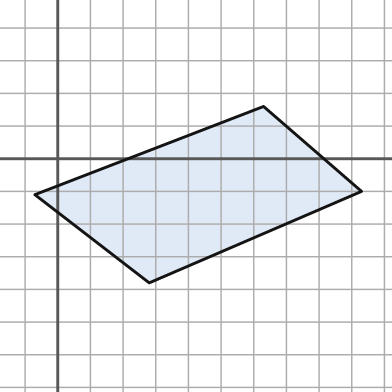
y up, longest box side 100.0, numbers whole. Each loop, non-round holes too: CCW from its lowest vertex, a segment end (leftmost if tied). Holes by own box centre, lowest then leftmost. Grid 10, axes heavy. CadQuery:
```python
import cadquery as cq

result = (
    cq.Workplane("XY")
    .moveTo(28.0, -38.0)
    .lineTo(93.0, -10.0)
    .lineTo(63.0, 16.0)
    .lineTo(-7.0, -11.0)
    .close()
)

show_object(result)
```